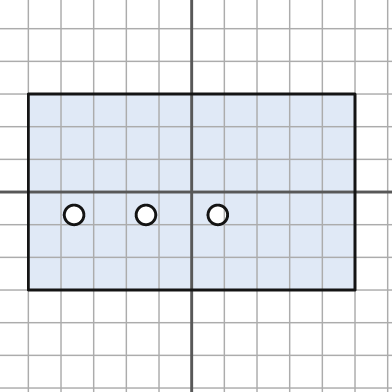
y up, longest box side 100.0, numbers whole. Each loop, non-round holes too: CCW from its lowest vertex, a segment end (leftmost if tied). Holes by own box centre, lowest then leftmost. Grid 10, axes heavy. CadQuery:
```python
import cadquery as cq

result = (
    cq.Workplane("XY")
    .moveTo(-50.0, -30.0)
    .lineTo(50.0, -30.0)
    .lineTo(50.0, 30.0)
    .lineTo(-50.0, 30.0)
    .close()
    .moveTo(-36.0, -7.0)
    .circle(3.0)
    .moveTo(-14.0, -7.0)
    .circle(3.0)
    .moveTo(8.0, -7.0)
    .circle(3.0)
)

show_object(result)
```